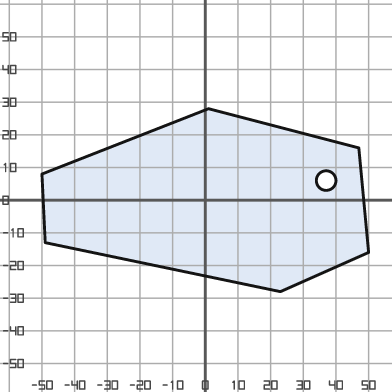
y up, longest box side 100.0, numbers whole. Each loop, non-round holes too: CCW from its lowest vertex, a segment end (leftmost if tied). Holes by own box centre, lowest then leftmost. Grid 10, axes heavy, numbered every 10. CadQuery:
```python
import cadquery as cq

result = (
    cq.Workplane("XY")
    .moveTo(23.0, -28.0)
    .lineTo(50.0, -16.0)
    .lineTo(47.0, 16.0)
    .lineTo(1.0, 28.0)
    .lineTo(-50.0, 8.0)
    .lineTo(-49.0, -13.0)
    .close()
    .moveTo(37.0, 6.0)
    .circle(3.0)
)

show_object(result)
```